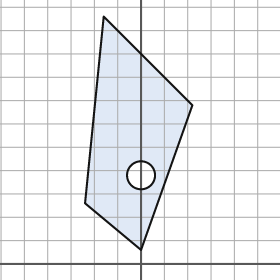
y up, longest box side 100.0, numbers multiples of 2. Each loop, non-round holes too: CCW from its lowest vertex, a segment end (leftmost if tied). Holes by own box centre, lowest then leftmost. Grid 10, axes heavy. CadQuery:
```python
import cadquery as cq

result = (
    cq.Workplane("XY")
    .moveTo(0.0, 6.0)
    .lineTo(22.0, 68.0)
    .lineTo(-16.0, 106.0)
    .lineTo(-24.0, 26.0)
    .close()
    .moveTo(0.0, 38.0)
    .circle(6.0)
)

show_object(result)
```